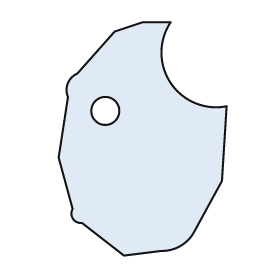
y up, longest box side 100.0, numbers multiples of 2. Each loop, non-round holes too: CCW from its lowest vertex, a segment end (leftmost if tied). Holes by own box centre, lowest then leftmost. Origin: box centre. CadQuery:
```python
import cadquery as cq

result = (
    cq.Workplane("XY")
    .moveTo(-8.0, -50.0)
    .lineTo(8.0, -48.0)
    .threePointArc((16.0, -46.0), (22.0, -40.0))
    .lineTo(34.0, -18.0)
    .lineTo(36.0, 14.0)
    .threePointArc((12.0, 24.0), (12.0, 50.0))
    .lineTo(0.0, 50.0)
    .lineTo(-12.0, 46.0)
    .lineTo(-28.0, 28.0)
    .threePointArc((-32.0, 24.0), (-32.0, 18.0))
    .lineTo(-36.0, -8.0)
    .lineTo(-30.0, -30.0)
    .threePointArc((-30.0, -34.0), (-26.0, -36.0))
    .close()
    .moveTo(-16.0, 12.0)
    .circle(6.0)
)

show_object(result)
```